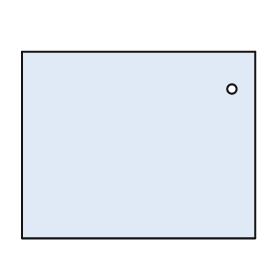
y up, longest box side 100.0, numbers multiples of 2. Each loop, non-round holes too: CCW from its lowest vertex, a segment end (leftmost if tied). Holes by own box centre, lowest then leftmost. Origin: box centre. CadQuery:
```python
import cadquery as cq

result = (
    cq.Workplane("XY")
    .moveTo(-50.0, -40.0)
    .lineTo(50.0, -40.0)
    .lineTo(50.0, 40.0)
    .lineTo(-50.0, 40.0)
    .close()
    .moveTo(40.0, 24.0)
    .circle(2.0)
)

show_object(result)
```